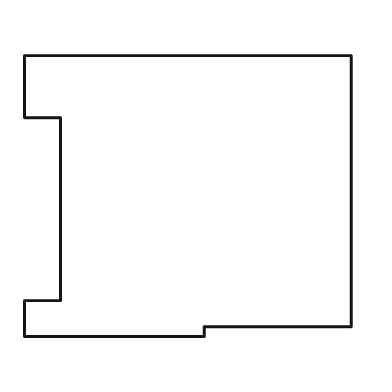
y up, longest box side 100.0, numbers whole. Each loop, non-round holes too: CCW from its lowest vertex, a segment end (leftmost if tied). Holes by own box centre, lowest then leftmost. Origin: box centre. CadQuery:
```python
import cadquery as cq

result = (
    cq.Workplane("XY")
    .moveTo(-50.0, -43.0)
    .lineTo(5.0, -43.0)
    .lineTo(5.0, -40.0)
    .lineTo(50.0, -40.0)
    .lineTo(50.0, 43.0)
    .lineTo(-50.0, 43.0)
    .lineTo(-50.0, 24.0)
    .lineTo(-39.0, 24.0)
    .lineTo(-39.0, -32.0)
    .lineTo(-50.0, -32.0)
    .close()
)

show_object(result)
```